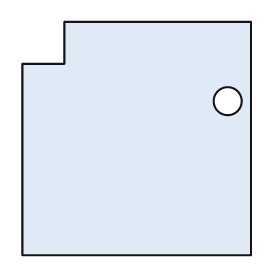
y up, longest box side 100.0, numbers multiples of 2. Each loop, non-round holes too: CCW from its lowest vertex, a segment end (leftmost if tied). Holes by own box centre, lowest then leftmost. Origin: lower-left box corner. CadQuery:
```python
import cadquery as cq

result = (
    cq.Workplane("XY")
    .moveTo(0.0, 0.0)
    .lineTo(98.0, 0.0)
    .lineTo(98.0, 100.0)
    .lineTo(18.0, 100.0)
    .lineTo(18.0, 82.0)
    .lineTo(0.0, 82.0)
    .close()
    .moveTo(88.0, 66.0)
    .circle(6.0)
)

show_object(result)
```